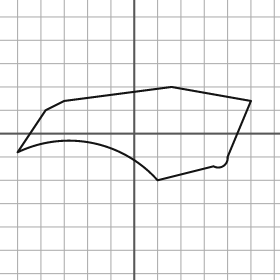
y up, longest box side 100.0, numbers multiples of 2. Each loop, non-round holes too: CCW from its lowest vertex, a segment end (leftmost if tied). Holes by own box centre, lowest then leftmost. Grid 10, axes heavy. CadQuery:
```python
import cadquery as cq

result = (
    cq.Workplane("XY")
    .moveTo(10.0, -20.0)
    .lineTo(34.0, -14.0)
    .threePointArc((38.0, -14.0), (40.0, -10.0))
    .lineTo(50.0, 14.0)
    .lineTo(16.0, 20.0)
    .lineTo(-30.0, 14.0)
    .lineTo(-38.0, 10.0)
    .lineTo(-50.0, -8.0)
    .threePointArc((-18.0, -4.0), (10.0, -20.0))
    .close()
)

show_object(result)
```